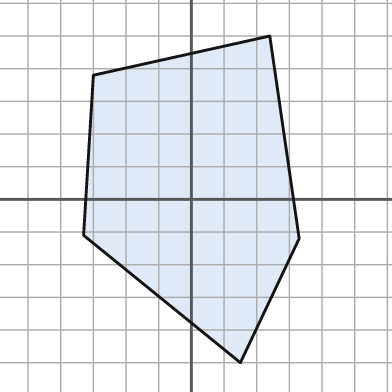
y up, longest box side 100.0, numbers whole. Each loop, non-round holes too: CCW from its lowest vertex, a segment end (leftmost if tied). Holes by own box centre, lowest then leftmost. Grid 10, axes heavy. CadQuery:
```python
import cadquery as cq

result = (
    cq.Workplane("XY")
    .moveTo(15.0, -50.0)
    .lineTo(33.0, -12.0)
    .lineTo(24.0, 50.0)
    .lineTo(-30.0, 38.0)
    .lineTo(-33.0, -11.0)
    .close()
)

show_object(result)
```